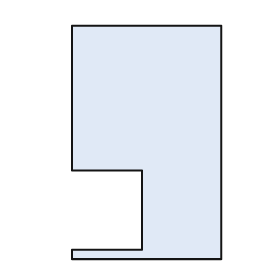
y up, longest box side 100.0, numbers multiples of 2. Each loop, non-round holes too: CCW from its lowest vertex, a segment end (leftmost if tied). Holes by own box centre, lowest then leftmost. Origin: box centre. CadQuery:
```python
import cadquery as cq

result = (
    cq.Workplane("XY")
    .moveTo(-32.0, -50.0)
    .lineTo(32.0, -50.0)
    .lineTo(32.0, 50.0)
    .lineTo(-32.0, 50.0)
    .lineTo(-32.0, -12.0)
    .lineTo(-2.0, -12.0)
    .lineTo(-2.0, -46.0)
    .lineTo(-32.0, -46.0)
    .close()
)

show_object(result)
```